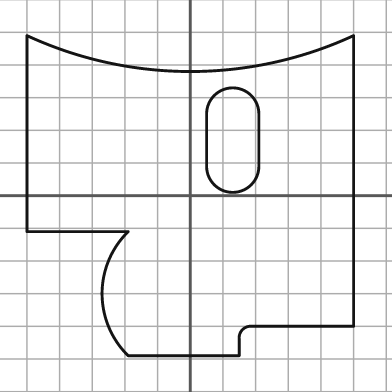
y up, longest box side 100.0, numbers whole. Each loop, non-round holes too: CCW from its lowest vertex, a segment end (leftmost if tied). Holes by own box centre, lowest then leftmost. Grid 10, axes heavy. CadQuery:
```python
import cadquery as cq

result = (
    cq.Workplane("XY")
    .moveTo(-19.0, -49.0)
    .lineTo(15.0, -49.0)
    .lineTo(15.0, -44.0)
    .threePointArc((16.0, -41.0), (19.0, -40.0))
    .lineTo(50.0, -40.0)
    .lineTo(50.0, 49.0)
    .threePointArc((0.0, 38.0), (-50.0, 49.0))
    .lineTo(-50.0, -11.0)
    .lineTo(-19.0, -11.0)
    .threePointArc((-27.0, -30.0), (-19.0, -49.0))
    .close()
    .moveTo(5.0, 9.0)
    .threePointArc((13.0, 1.0), (21.0, 9.0))
    .lineTo(21.0, 25.0)
    .threePointArc((13.0, 33.0), (5.0, 25.0))
    .close()
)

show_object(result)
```